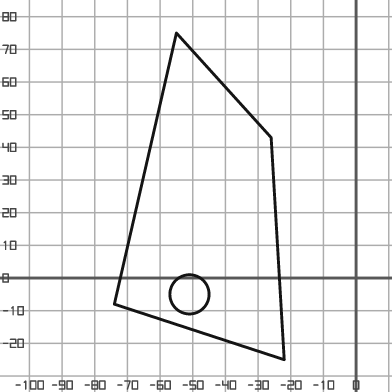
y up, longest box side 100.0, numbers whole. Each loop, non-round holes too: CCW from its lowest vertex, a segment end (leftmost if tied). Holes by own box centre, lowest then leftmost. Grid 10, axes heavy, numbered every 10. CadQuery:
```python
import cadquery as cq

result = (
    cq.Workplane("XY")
    .moveTo(-22.0, -25.0)
    .lineTo(-26.0, 43.0)
    .lineTo(-55.0, 75.0)
    .lineTo(-74.0, -8.0)
    .close()
    .moveTo(-51.0, -5.0)
    .circle(6.0)
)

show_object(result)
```